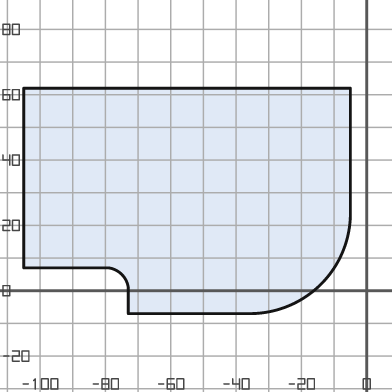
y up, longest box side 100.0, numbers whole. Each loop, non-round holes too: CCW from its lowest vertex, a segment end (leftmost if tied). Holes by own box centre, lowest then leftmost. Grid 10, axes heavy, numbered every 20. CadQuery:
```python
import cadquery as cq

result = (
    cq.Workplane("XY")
    .moveTo(-73.0, -7.0)
    .lineTo(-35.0, -7.0)
    .threePointArc((-14.0, 2.0), (-5.0, 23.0))
    .lineTo(-5.0, 62.0)
    .lineTo(-105.0, 62.0)
    .lineTo(-105.0, 7.0)
    .lineTo(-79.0, 7.0)
    .threePointArc((-75.0, 5.0), (-73.0, 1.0))
    .close()
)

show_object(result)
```